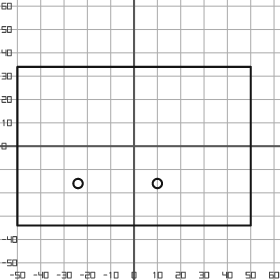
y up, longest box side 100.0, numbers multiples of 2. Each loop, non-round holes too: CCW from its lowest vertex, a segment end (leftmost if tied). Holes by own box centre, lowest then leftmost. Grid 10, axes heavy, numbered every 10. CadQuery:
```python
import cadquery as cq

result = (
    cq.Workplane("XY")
    .moveTo(-50.0, -34.0)
    .lineTo(50.0, -34.0)
    .lineTo(50.0, 34.0)
    .lineTo(-50.0, 34.0)
    .close()
    .moveTo(-24.0, -16.0)
    .circle(2.0)
    .moveTo(10.0, -16.0)
    .circle(2.0)
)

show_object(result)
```